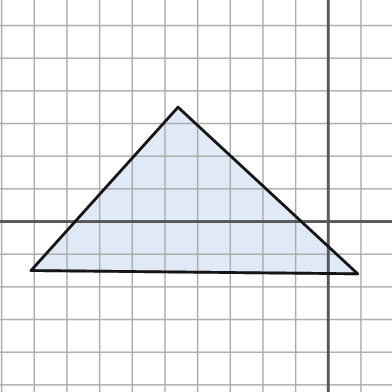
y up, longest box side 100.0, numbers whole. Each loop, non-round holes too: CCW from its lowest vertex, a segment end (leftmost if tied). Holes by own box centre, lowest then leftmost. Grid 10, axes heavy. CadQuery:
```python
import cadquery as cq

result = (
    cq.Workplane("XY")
    .moveTo(9.0, -16.0)
    .lineTo(-46.0, 35.0)
    .lineTo(-91.0, -15.0)
    .close()
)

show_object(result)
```